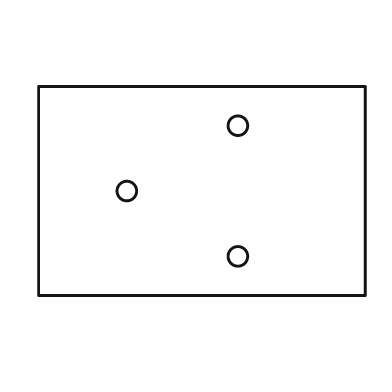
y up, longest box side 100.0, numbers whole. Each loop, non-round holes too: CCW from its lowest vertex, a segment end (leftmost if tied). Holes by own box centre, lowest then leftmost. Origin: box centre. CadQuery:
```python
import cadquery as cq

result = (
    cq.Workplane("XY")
    .moveTo(-50.0, -32.0)
    .lineTo(50.0, -32.0)
    .lineTo(50.0, 32.0)
    .lineTo(-50.0, 32.0)
    .close()
    .moveTo(11.0, -20.0)
    .circle(3.0)
    .moveTo(-23.0, 0.0)
    .circle(3.0)
    .moveTo(11.0, 20.0)
    .circle(3.0)
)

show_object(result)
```